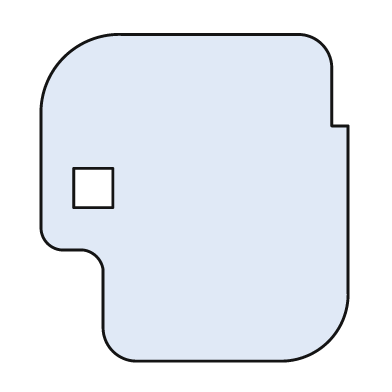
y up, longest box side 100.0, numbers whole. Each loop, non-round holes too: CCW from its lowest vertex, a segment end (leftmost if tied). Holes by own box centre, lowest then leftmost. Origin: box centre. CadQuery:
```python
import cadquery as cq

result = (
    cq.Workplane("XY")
    .moveTo(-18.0, -50.0)
    .lineTo(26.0, -50.0)
    .threePointArc((41.0, -44.0), (47.0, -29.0))
    .lineTo(47.0, 22.0)
    .lineTo(42.0, 22.0)
    .lineTo(42.0, 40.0)
    .threePointArc((39.0, 47.0), (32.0, 50.0))
    .lineTo(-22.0, 50.0)
    .threePointArc((-40.0, 43.0), (-47.0, 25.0))
    .lineTo(-47.0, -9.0)
    .threePointArc((-45.0, -14.0), (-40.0, -16.0))
    .lineTo(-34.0, -16.0)
    .threePointArc((-30.0, -18.0), (-28.0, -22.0))
    .lineTo(-28.0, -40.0)
    .threePointArc((-25.0, -47.0), (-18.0, -50.0))
    .close()
    .moveTo(-37.0, -3.0)
    .lineTo(-25.0, -3.0)
    .lineTo(-25.0, 9.0)
    .lineTo(-37.0, 9.0)
    .close()
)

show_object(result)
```